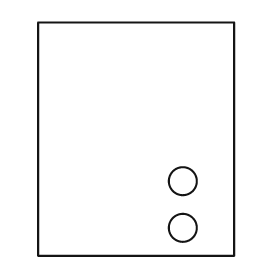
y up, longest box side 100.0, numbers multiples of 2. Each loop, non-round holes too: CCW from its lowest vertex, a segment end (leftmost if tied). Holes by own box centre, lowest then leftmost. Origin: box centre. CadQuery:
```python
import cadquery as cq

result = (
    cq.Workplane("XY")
    .moveTo(-42.0, -50.0)
    .lineTo(42.0, -50.0)
    .lineTo(42.0, 50.0)
    .lineTo(-42.0, 50.0)
    .close()
    .moveTo(20.0, -38.0)
    .circle(6.0)
    .moveTo(20.0, -18.0)
    .circle(6.0)
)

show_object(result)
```